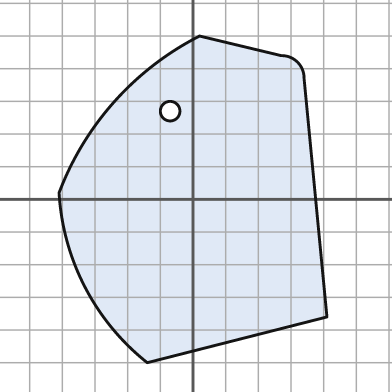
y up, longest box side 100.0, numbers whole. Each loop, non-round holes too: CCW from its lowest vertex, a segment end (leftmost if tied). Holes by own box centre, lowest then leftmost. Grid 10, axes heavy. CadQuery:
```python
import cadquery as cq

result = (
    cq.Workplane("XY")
    .moveTo(-14.0, -50.0)
    .lineTo(41.0, -36.0)
    .lineTo(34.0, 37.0)
    .threePointArc((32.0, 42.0), (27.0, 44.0))
    .lineTo(2.0, 50.0)
    .threePointArc((-24.0, 30.0), (-41.0, 2.0))
    .threePointArc((-33.0, -27.0), (-14.0, -50.0))
    .close()
    .moveTo(-7.0, 27.0)
    .circle(3.0)
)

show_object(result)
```